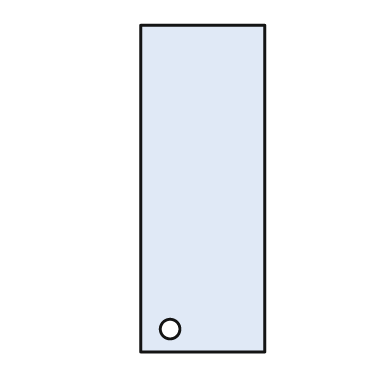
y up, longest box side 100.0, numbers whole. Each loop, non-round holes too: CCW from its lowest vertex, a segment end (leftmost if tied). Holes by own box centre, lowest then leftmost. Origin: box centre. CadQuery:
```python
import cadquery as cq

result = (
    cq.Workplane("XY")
    .moveTo(-19.0, -50.0)
    .lineTo(19.0, -50.0)
    .lineTo(19.0, 50.0)
    .lineTo(-19.0, 50.0)
    .close()
    .moveTo(-10.0, -43.0)
    .circle(3.0)
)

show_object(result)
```